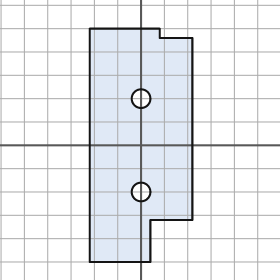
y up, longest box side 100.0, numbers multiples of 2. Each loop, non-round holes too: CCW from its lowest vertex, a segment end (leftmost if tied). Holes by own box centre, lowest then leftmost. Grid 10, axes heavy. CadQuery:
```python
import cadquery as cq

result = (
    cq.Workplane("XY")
    .moveTo(-22.0, -50.0)
    .lineTo(4.0, -50.0)
    .lineTo(4.0, -32.0)
    .lineTo(22.0, -32.0)
    .lineTo(22.0, 46.0)
    .lineTo(8.0, 46.0)
    .lineTo(8.0, 50.0)
    .lineTo(-22.0, 50.0)
    .close()
    .moveTo(0.0, -20.0)
    .circle(4.0)
    .moveTo(0.0, 20.0)
    .circle(4.0)
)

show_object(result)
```